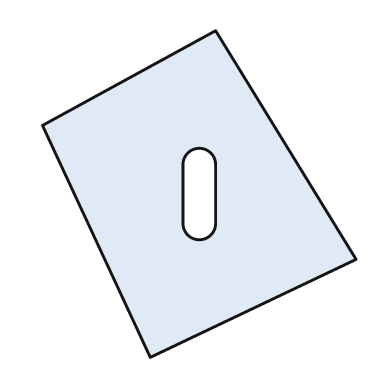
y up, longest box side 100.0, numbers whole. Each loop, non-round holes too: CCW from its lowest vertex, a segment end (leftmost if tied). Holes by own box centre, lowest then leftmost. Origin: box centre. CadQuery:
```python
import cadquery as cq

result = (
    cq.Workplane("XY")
    .moveTo(-15.0, -50.0)
    .lineTo(48.0, -20.0)
    .lineTo(5.0, 50.0)
    .lineTo(-48.0, 21.0)
    .close()
    .moveTo(-5.0, -9.0)
    .threePointArc((0.0, -14.0), (5.0, -9.0))
    .lineTo(5.0, 9.0)
    .threePointArc((0.0, 14.0), (-5.0, 9.0))
    .close()
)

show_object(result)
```